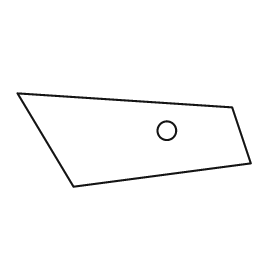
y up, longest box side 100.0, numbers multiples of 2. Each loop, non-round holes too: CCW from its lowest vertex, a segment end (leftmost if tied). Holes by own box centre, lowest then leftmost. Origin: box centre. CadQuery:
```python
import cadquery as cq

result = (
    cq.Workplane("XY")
    .moveTo(-26.0, -20.0)
    .lineTo(50.0, -10.0)
    .lineTo(42.0, 14.0)
    .lineTo(-50.0, 20.0)
    .close()
    .moveTo(14.0, 4.0)
    .circle(4.0)
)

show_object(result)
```